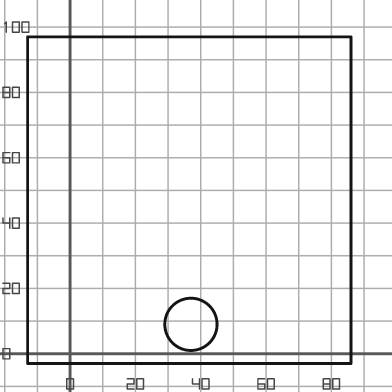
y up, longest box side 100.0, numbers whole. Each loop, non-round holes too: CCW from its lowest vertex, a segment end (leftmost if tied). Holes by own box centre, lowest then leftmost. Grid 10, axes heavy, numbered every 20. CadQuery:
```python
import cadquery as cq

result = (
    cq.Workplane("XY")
    .moveTo(-13.0, -3.0)
    .lineTo(86.0, -3.0)
    .lineTo(86.0, 97.0)
    .lineTo(-13.0, 97.0)
    .close()
    .moveTo(37.0, 9.0)
    .circle(8.0)
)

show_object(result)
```